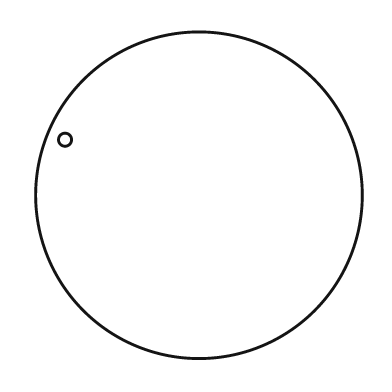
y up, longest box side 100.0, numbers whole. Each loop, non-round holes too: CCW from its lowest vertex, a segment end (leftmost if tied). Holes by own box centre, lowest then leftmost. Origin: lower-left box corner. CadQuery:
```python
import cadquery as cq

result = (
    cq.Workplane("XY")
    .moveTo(50.0, 50.0)
    .circle(50.0)
    .moveTo(9.0, 67.0)
    .circle(2.0)
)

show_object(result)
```